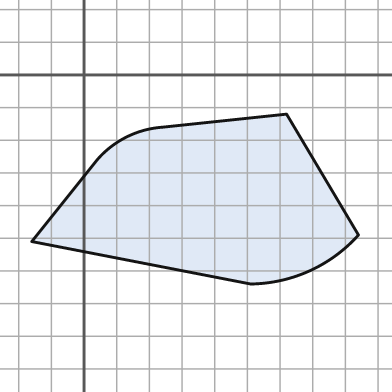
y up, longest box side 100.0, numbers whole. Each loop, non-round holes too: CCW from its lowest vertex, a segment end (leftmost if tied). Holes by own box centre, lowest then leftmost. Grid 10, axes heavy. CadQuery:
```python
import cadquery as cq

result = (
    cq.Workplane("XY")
    .moveTo(51.0, -64.0)
    .threePointArc((69.0, -60.0), (84.0, -49.0))
    .lineTo(62.0, -12.0)
    .lineTo(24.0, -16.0)
    .threePointArc((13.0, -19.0), (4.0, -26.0))
    .lineTo(-16.0, -51.0)
    .close()
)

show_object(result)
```